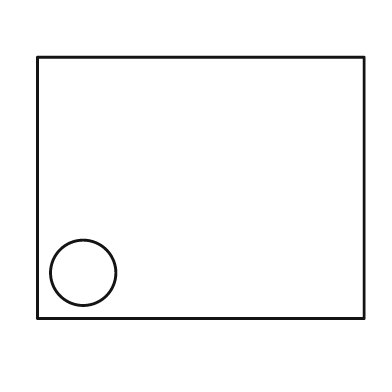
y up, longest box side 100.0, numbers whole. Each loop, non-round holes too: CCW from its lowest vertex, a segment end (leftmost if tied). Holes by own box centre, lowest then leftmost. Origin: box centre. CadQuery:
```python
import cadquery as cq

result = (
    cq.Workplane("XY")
    .moveTo(-50.0, -40.0)
    .lineTo(50.0, -40.0)
    .lineTo(50.0, 40.0)
    .lineTo(-50.0, 40.0)
    .close()
    .moveTo(-36.0, -26.0)
    .circle(10.0)
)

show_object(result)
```